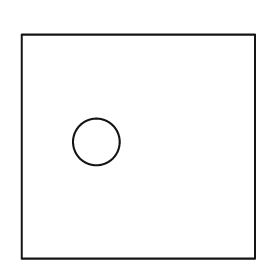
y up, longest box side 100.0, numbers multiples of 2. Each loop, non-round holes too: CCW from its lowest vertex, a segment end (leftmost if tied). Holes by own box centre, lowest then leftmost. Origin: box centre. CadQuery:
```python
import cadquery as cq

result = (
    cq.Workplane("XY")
    .moveTo(-50.0, -48.0)
    .lineTo(50.0, -48.0)
    .lineTo(50.0, 48.0)
    .lineTo(-50.0, 48.0)
    .close()
    .moveTo(-18.0, 2.0)
    .circle(10.0)
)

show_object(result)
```